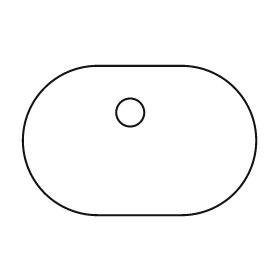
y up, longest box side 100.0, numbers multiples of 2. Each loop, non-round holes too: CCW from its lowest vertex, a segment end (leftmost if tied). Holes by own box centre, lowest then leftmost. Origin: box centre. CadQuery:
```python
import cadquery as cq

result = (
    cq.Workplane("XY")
    .moveTo(-18.0, -32.0)
    .lineTo(18.0, -32.0)
    .threePointArc((50.0, 0.0), (18.0, 32.0))
    .lineTo(-18.0, 32.0)
    .threePointArc((-50.0, 0.0), (-18.0, -32.0))
    .close()
    .moveTo(-4.0, 12.0)
    .circle(6.0)
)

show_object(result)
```